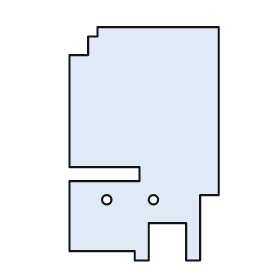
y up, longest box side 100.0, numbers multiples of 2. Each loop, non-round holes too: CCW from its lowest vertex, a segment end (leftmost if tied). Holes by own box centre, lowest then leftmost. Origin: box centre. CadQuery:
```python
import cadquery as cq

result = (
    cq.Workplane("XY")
    .moveTo(-4.0, -50.0)
    .lineTo(2.0, -50.0)
    .lineTo(2.0, -34.0)
    .lineTo(18.0, -34.0)
    .lineTo(18.0, -50.0)
    .lineTo(24.0, -50.0)
    .lineTo(24.0, -22.0)
    .lineTo(32.0, -22.0)
    .lineTo(32.0, 50.0)
    .lineTo(-20.0, 50.0)
    .lineTo(-20.0, 46.0)
    .lineTo(-24.0, 46.0)
    .lineTo(-24.0, 38.0)
    .lineTo(-32.0, 38.0)
    .lineTo(-32.0, -10.0)
    .lineTo(-2.0, -10.0)
    .lineTo(-2.0, -16.0)
    .lineTo(-32.0, -16.0)
    .lineTo(-32.0, -46.0)
    .lineTo(-4.0, -46.0)
    .close()
    .moveTo(-16.0, -24.0)
    .circle(2.0)
    .moveTo(4.0, -24.0)
    .circle(2.0)
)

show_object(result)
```